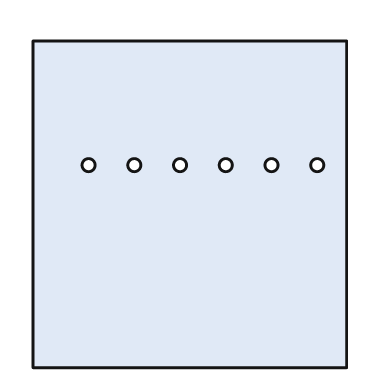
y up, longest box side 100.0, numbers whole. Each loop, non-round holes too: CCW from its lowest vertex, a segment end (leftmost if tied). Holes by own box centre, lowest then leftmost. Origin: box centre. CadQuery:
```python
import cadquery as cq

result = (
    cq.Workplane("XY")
    .moveTo(-48.0, -50.0)
    .lineTo(48.0, -50.0)
    .lineTo(48.0, 50.0)
    .lineTo(-48.0, 50.0)
    .close()
    .moveTo(-31.0, 12.0)
    .circle(2.0)
    .moveTo(-17.0, 12.0)
    .circle(2.0)
    .moveTo(-3.0, 12.0)
    .circle(2.0)
    .moveTo(11.0, 12.0)
    .circle(2.0)
    .moveTo(25.0, 12.0)
    .circle(2.0)
    .moveTo(39.0, 12.0)
    .circle(2.0)
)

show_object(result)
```